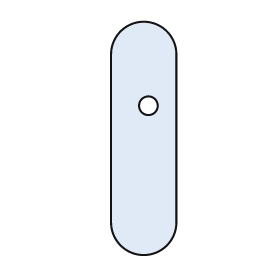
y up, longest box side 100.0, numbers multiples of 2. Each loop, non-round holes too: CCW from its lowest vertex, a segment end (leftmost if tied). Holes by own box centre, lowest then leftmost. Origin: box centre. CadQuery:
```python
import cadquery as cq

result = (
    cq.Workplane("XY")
    .moveTo(-14.0, -36.0)
    .threePointArc((0.0, -50.0), (14.0, -36.0))
    .lineTo(14.0, 36.0)
    .threePointArc((0.0, 50.0), (-14.0, 36.0))
    .close()
    .moveTo(2.0, 14.0)
    .circle(4.0)
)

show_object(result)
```